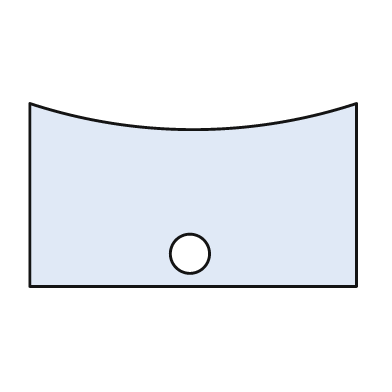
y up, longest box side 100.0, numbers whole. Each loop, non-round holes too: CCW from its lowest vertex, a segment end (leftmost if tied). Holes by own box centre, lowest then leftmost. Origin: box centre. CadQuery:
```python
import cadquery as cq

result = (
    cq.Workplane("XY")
    .moveTo(-50.0, -28.0)
    .lineTo(50.0, -28.0)
    .lineTo(50.0, 28.0)
    .threePointArc((0.0, 20.0), (-50.0, 28.0))
    .close()
    .moveTo(-1.0, -18.0)
    .circle(6.0)
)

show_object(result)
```